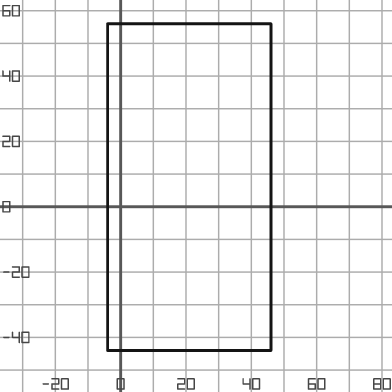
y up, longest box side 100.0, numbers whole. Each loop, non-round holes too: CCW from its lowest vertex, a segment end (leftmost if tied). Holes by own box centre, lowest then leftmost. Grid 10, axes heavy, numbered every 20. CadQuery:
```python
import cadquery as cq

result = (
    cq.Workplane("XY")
    .moveTo(-4.0, -44.0)
    .lineTo(46.0, -44.0)
    .lineTo(46.0, 56.0)
    .lineTo(-4.0, 56.0)
    .close()
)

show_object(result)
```